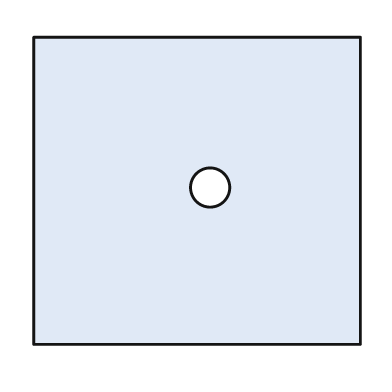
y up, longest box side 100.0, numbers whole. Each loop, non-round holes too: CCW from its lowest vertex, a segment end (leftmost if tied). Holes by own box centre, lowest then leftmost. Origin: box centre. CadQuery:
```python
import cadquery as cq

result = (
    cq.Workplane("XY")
    .moveTo(-50.0, -47.0)
    .lineTo(50.0, -47.0)
    .lineTo(50.0, 47.0)
    .lineTo(-50.0, 47.0)
    .close()
    .moveTo(4.0, 1.0)
    .circle(6.0)
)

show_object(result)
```